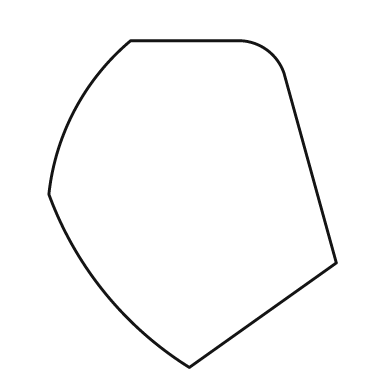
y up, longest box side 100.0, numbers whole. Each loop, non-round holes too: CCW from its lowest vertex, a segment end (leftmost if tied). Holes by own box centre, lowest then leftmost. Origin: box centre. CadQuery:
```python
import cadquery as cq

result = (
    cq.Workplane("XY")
    .moveTo(-1.0, -50.0)
    .lineTo(44.0, -18.0)
    .lineTo(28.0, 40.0)
    .threePointArc((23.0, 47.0), (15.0, 50.0))
    .lineTo(-19.0, 50.0)
    .threePointArc((-36.0, 29.0), (-44.0, 3.0))
    .threePointArc((-27.0, -27.0), (-1.0, -50.0))
    .close()
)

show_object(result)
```